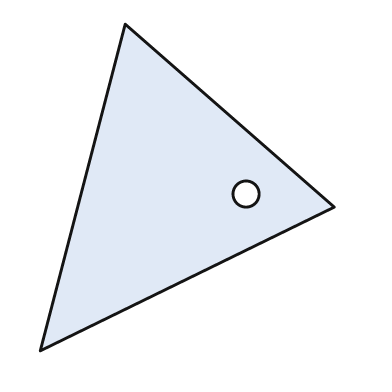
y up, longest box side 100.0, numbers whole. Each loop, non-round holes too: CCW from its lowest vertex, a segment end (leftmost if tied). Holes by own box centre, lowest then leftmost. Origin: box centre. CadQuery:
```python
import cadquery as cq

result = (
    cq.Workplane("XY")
    .moveTo(-45.0, -50.0)
    .lineTo(45.0, -6.0)
    .lineTo(-19.0, 50.0)
    .close()
    .moveTo(18.0, -2.0)
    .circle(4.0)
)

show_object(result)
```